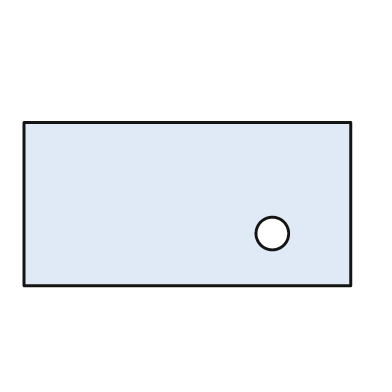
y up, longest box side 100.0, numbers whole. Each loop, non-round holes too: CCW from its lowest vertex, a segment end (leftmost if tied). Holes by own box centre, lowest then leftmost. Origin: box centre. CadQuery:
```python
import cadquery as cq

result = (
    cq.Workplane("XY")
    .moveTo(-50.0, -25.0)
    .lineTo(50.0, -25.0)
    .lineTo(50.0, 25.0)
    .lineTo(-50.0, 25.0)
    .close()
    .moveTo(26.0, -9.0)
    .circle(5.0)
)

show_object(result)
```